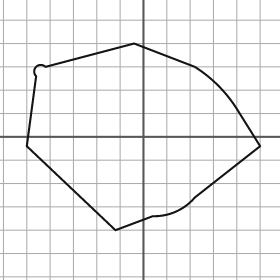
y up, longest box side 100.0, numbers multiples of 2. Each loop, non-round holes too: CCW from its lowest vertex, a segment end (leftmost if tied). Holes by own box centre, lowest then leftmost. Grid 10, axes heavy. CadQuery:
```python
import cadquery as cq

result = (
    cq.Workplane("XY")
    .moveTo(-12.0, -40.0)
    .lineTo(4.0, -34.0)
    .threePointArc((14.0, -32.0), (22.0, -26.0))
    .lineTo(50.0, -4.0)
    .lineTo(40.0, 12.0)
    .threePointArc((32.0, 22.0), (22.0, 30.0))
    .lineTo(-4.0, 40.0)
    .lineTo(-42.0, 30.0)
    .threePointArc((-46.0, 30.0), (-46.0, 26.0))
    .lineTo(-50.0, -4.0)
    .close()
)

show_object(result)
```